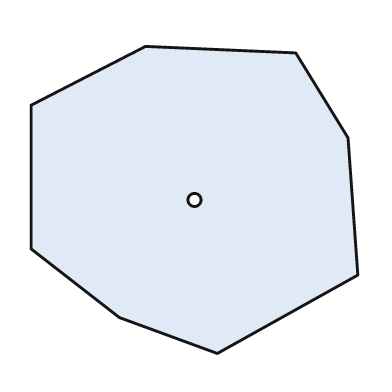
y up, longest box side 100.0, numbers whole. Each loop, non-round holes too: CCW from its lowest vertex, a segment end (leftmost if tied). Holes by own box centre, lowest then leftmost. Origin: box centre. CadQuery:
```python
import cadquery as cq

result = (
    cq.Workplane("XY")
    .moveTo(7.0, -47.0)
    .lineTo(50.0, -23.0)
    .lineTo(47.0, 19.0)
    .lineTo(31.0, 45.0)
    .lineTo(-15.0, 47.0)
    .lineTo(-50.0, 29.0)
    .lineTo(-50.0, -15.0)
    .lineTo(-23.0, -36.0)
    .close()
    .moveTo(0.0, 0.0)
    .circle(2.0)
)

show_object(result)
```